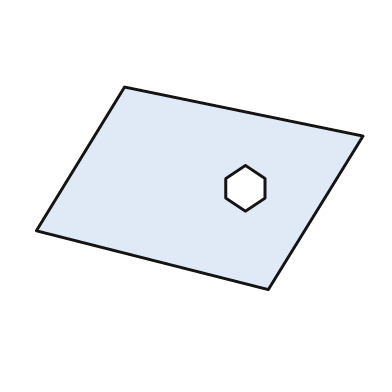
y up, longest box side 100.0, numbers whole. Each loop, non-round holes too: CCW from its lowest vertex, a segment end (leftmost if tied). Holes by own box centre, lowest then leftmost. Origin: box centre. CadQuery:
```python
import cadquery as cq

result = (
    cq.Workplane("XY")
    .moveTo(21.0, -31.0)
    .lineTo(50.0, 16.0)
    .lineTo(-23.0, 31.0)
    .lineTo(-50.0, -13.0)
    .close()
    .moveTo(14.0, -7.0)
    .lineTo(20.0, -3.0)
    .lineTo(20.0, 3.0)
    .lineTo(14.0, 7.0)
    .lineTo(8.0, 3.0)
    .lineTo(8.0, -3.0)
    .close()
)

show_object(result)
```